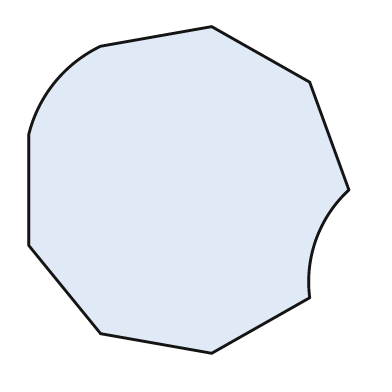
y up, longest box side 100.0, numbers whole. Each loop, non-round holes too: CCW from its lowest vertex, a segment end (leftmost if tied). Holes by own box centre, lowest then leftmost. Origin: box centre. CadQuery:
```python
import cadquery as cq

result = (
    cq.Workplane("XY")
    .moveTo(7.0, -50.0)
    .lineTo(37.0, -33.0)
    .threePointArc((39.0, -15.0), (49.0, 0.0))
    .lineTo(37.0, 33.0)
    .lineTo(7.0, 50.0)
    .lineTo(-27.0, 44.0)
    .threePointArc((-41.0, 33.0), (-49.0, 17.0))
    .lineTo(-49.0, -17.0)
    .lineTo(-27.0, -44.0)
    .close()
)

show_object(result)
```